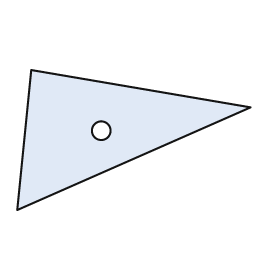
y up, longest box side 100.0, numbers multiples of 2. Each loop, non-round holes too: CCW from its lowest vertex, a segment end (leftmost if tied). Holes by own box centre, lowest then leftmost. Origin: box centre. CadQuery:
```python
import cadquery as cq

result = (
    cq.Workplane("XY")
    .moveTo(-50.0, -30.0)
    .lineTo(50.0, 14.0)
    .lineTo(-44.0, 30.0)
    .close()
    .moveTo(-14.0, 4.0)
    .circle(4.0)
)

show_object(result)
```